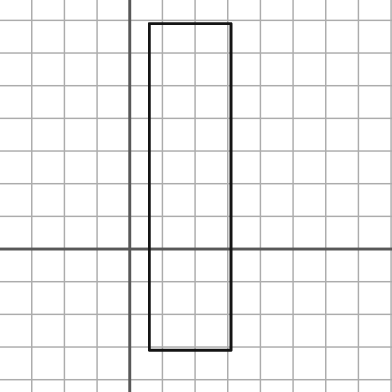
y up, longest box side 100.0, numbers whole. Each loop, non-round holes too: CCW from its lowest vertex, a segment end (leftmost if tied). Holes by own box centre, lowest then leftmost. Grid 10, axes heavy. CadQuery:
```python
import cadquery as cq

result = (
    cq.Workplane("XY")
    .moveTo(6.0, -31.0)
    .lineTo(31.0, -31.0)
    .lineTo(31.0, 69.0)
    .lineTo(6.0, 69.0)
    .close()
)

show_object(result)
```